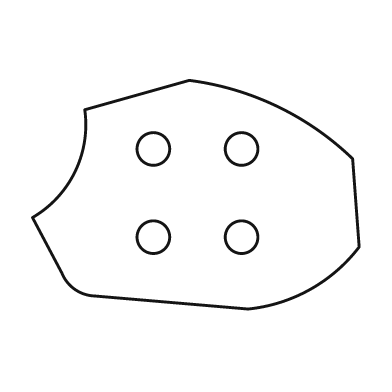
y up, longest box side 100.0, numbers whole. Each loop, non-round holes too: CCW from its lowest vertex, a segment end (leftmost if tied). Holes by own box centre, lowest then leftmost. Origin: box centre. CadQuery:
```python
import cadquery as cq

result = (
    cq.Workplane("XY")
    .moveTo(16.0, -35.0)
    .threePointArc((35.0, -29.0), (50.0, -16.0))
    .lineTo(48.0, 11.0)
    .threePointArc((25.0, 27.0), (-2.0, 35.0))
    .lineTo(-34.0, 26.0)
    .threePointArc((-37.0, 7.0), (-50.0, -7.0))
    .lineTo(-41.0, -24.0)
    .threePointArc((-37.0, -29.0), (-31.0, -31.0))
    .close()
    .moveTo(-13.0, -13.0)
    .circle(5.0)
    .moveTo(14.0, -13.0)
    .circle(5.0)
    .moveTo(-13.0, 14.0)
    .circle(5.0)
    .moveTo(14.0, 14.0)
    .circle(5.0)
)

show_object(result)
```